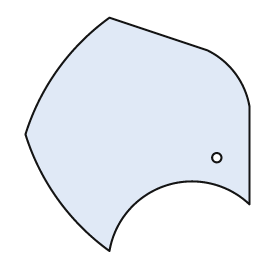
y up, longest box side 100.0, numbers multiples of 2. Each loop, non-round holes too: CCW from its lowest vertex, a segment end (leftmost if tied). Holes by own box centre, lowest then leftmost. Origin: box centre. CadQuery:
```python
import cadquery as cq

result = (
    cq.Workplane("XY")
    .moveTo(-12.0, -50.0)
    .threePointArc((12.0, -22.0), (48.0, -30.0))
    .lineTo(48.0, 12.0)
    .threePointArc((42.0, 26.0), (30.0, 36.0))
    .lineTo(-12.0, 50.0)
    .threePointArc((-34.0, 28.0), (-48.0, 0.0))
    .threePointArc((-34.0, -28.0), (-12.0, -50.0))
    .close()
    .moveTo(34.0, -10.0)
    .circle(2.0)
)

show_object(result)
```